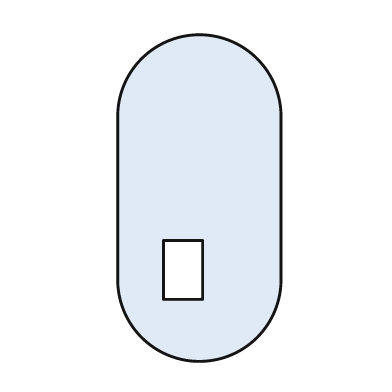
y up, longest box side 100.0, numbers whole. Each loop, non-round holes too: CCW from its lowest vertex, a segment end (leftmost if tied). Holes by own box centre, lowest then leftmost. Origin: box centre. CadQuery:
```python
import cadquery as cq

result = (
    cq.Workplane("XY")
    .moveTo(-25.0, -25.0)
    .threePointArc((0.0, -50.0), (25.0, -25.0))
    .lineTo(25.0, 25.0)
    .threePointArc((0.0, 50.0), (-25.0, 25.0))
    .close()
    .moveTo(-11.0, -31.0)
    .lineTo(1.0, -31.0)
    .lineTo(1.0, -13.0)
    .lineTo(-11.0, -13.0)
    .close()
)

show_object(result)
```